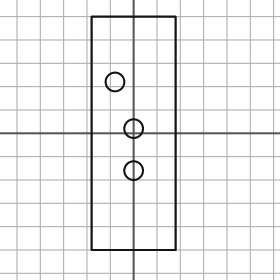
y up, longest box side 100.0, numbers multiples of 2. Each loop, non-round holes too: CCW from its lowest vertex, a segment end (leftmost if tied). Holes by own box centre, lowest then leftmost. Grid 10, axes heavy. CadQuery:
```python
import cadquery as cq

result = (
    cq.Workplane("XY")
    .moveTo(-18.0, -50.0)
    .lineTo(18.0, -50.0)
    .lineTo(18.0, 50.0)
    .lineTo(-18.0, 50.0)
    .close()
    .moveTo(0.0, -16.0)
    .circle(4.0)
    .moveTo(0.0, 2.0)
    .circle(4.0)
    .moveTo(-8.0, 22.0)
    .circle(4.0)
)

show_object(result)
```